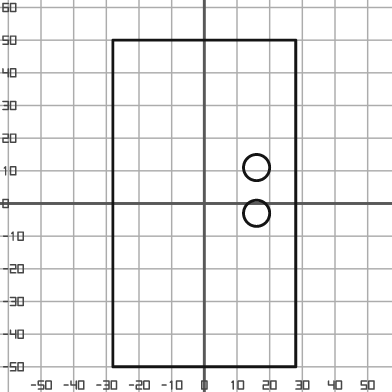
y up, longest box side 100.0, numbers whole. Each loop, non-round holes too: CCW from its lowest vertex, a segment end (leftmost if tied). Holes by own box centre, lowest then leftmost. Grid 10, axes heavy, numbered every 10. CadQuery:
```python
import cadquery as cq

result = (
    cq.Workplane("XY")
    .moveTo(-28.0, -50.0)
    .lineTo(28.0, -50.0)
    .lineTo(28.0, 50.0)
    .lineTo(-28.0, 50.0)
    .close()
    .moveTo(16.0, -3.0)
    .circle(4.0)
    .moveTo(16.0, 11.0)
    .circle(4.0)
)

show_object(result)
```